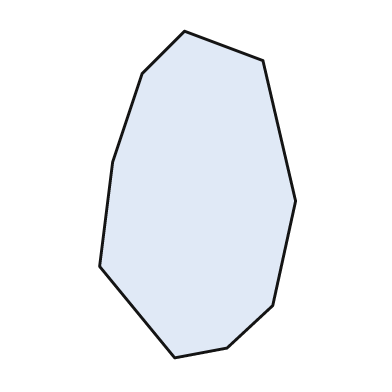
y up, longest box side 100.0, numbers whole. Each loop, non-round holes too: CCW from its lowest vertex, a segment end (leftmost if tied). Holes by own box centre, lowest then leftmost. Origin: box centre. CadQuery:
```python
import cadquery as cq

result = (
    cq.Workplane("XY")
    .moveTo(-7.0, -50.0)
    .lineTo(9.0, -47.0)
    .lineTo(23.0, -34.0)
    .lineTo(30.0, -2.0)
    .lineTo(20.0, 41.0)
    .lineTo(-4.0, 50.0)
    .lineTo(-17.0, 37.0)
    .lineTo(-26.0, 10.0)
    .lineTo(-30.0, -22.0)
    .close()
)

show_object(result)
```